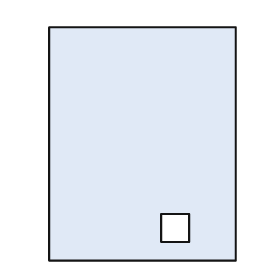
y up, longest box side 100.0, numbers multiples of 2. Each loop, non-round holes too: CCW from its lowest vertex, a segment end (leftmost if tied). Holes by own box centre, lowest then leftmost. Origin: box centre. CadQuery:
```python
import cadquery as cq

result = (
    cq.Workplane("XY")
    .moveTo(-40.0, -50.0)
    .lineTo(40.0, -50.0)
    .lineTo(40.0, 50.0)
    .lineTo(-40.0, 50.0)
    .close()
    .moveTo(8.0, -42.0)
    .lineTo(20.0, -42.0)
    .lineTo(20.0, -30.0)
    .lineTo(8.0, -30.0)
    .close()
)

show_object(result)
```